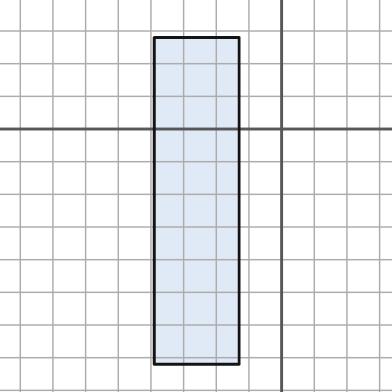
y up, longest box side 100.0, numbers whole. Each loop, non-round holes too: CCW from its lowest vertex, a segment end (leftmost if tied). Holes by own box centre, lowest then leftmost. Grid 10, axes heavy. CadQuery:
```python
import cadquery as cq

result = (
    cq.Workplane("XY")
    .moveTo(-39.0, -72.0)
    .lineTo(-13.0, -72.0)
    .lineTo(-13.0, 28.0)
    .lineTo(-39.0, 28.0)
    .close()
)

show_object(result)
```